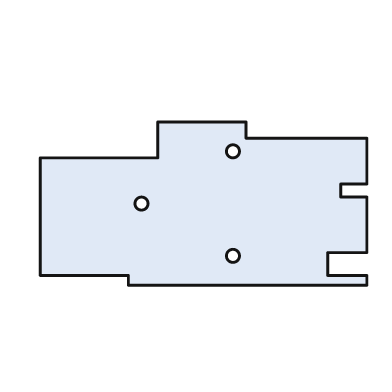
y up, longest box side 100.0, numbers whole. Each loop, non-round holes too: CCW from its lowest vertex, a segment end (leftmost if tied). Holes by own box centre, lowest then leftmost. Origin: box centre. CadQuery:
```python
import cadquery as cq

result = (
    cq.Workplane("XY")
    .moveTo(-23.0, -25.0)
    .lineTo(50.0, -25.0)
    .lineTo(50.0, -22.0)
    .lineTo(38.0, -22.0)
    .lineTo(38.0, -15.0)
    .lineTo(50.0, -15.0)
    .lineTo(50.0, 2.0)
    .lineTo(42.0, 2.0)
    .lineTo(42.0, 6.0)
    .lineTo(50.0, 6.0)
    .lineTo(50.0, 20.0)
    .lineTo(13.0, 20.0)
    .lineTo(13.0, 25.0)
    .lineTo(-14.0, 25.0)
    .lineTo(-14.0, 14.0)
    .lineTo(-50.0, 14.0)
    .lineTo(-50.0, -22.0)
    .lineTo(-23.0, -22.0)
    .close()
    .moveTo(9.0, -16.0)
    .circle(2.0)
    .moveTo(-19.0, 0.0)
    .circle(2.0)
    .moveTo(9.0, 16.0)
    .circle(2.0)
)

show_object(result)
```